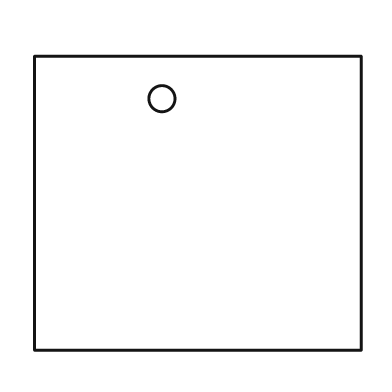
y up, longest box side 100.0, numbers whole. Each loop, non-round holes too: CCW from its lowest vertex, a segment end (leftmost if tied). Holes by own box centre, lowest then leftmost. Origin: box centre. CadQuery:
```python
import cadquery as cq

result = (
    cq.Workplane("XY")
    .moveTo(-50.0, -45.0)
    .lineTo(50.0, -45.0)
    .lineTo(50.0, 45.0)
    .lineTo(-50.0, 45.0)
    .close()
    .moveTo(-11.0, 32.0)
    .circle(4.0)
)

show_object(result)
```